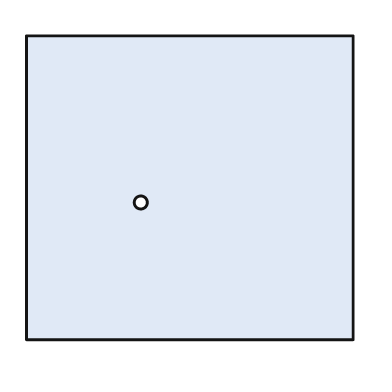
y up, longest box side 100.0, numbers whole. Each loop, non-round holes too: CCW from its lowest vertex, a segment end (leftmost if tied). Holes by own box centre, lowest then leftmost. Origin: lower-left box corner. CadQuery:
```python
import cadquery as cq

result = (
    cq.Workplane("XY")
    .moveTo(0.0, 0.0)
    .lineTo(100.0, 0.0)
    .lineTo(100.0, 93.0)
    .lineTo(0.0, 93.0)
    .close()
    .moveTo(35.0, 42.0)
    .circle(2.0)
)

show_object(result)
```